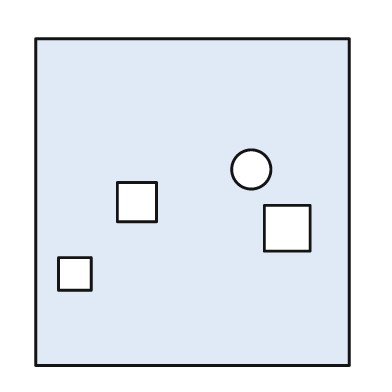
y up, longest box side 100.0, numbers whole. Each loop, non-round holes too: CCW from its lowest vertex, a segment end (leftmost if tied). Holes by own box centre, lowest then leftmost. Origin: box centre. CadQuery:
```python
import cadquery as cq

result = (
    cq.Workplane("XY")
    .moveTo(-48.0, -50.0)
    .lineTo(48.0, -50.0)
    .lineTo(48.0, 50.0)
    .lineTo(-48.0, 50.0)
    .close()
    .moveTo(-41.0, -27.0)
    .lineTo(-31.0, -27.0)
    .lineTo(-31.0, -17.0)
    .lineTo(-41.0, -17.0)
    .close()
    .moveTo(22.0, -15.0)
    .lineTo(36.0, -15.0)
    .lineTo(36.0, -1.0)
    .lineTo(22.0, -1.0)
    .close()
    .moveTo(-23.0, -6.0)
    .lineTo(-11.0, -6.0)
    .lineTo(-11.0, 6.0)
    .lineTo(-23.0, 6.0)
    .close()
    .moveTo(18.0, 10.0)
    .circle(6.0)
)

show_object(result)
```